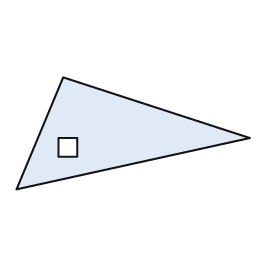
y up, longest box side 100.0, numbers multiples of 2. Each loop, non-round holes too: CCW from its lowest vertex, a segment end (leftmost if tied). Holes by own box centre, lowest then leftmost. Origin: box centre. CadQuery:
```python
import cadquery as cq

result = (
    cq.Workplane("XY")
    .moveTo(-50.0, -24.0)
    .lineTo(50.0, -2.0)
    .lineTo(-30.0, 24.0)
    .close()
    .moveTo(-32.0, -10.0)
    .lineTo(-24.0, -10.0)
    .lineTo(-24.0, -2.0)
    .lineTo(-32.0, -2.0)
    .close()
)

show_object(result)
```